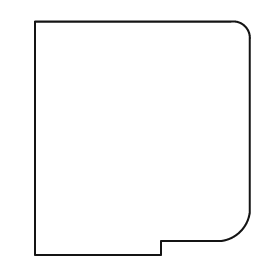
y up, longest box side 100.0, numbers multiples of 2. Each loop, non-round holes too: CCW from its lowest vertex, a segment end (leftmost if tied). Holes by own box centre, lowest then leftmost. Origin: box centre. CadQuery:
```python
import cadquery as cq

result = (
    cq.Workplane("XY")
    .moveTo(-46.0, -50.0)
    .lineTo(8.0, -50.0)
    .lineTo(8.0, -44.0)
    .lineTo(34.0, -44.0)
    .threePointArc((42.0, -40.0), (46.0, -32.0))
    .lineTo(46.0, 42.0)
    .threePointArc((44.0, 48.0), (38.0, 50.0))
    .lineTo(-46.0, 50.0)
    .close()
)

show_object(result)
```